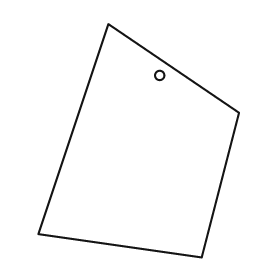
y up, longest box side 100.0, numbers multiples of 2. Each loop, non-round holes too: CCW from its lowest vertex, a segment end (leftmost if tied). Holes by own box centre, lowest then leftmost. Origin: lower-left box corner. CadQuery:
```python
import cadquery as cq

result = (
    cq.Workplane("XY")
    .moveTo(70.0, 0.0)
    .lineTo(86.0, 62.0)
    .lineTo(30.0, 100.0)
    .lineTo(0.0, 10.0)
    .close()
    .moveTo(52.0, 78.0)
    .circle(2.0)
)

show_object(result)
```